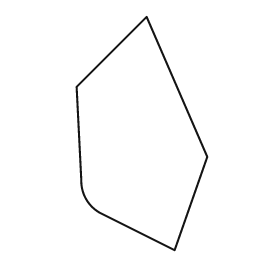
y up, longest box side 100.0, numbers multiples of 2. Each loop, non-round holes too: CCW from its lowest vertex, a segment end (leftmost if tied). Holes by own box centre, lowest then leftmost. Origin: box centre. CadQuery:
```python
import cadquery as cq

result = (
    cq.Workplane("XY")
    .moveTo(14.0, -50.0)
    .lineTo(28.0, -10.0)
    .lineTo(2.0, 50.0)
    .lineTo(-28.0, 20.0)
    .lineTo(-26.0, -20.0)
    .threePointArc((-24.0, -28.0), (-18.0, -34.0))
    .close()
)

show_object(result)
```